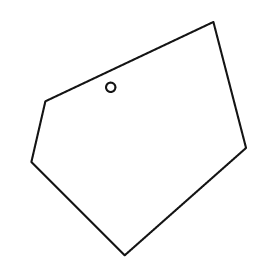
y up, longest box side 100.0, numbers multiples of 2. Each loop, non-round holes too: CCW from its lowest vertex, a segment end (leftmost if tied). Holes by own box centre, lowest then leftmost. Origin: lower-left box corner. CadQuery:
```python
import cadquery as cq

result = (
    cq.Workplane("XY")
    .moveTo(40.0, 0.0)
    .lineTo(92.0, 46.0)
    .lineTo(78.0, 100.0)
    .lineTo(6.0, 66.0)
    .lineTo(0.0, 40.0)
    .close()
    .moveTo(34.0, 72.0)
    .circle(2.0)
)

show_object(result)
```